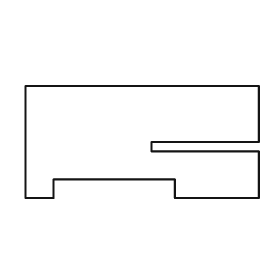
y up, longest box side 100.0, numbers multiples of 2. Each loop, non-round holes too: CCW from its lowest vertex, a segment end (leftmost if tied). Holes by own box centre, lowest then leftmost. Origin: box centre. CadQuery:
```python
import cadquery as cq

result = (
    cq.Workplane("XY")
    .moveTo(-50.0, -24.0)
    .lineTo(-38.0, -24.0)
    .lineTo(-38.0, -16.0)
    .lineTo(14.0, -16.0)
    .lineTo(14.0, -24.0)
    .lineTo(50.0, -24.0)
    .lineTo(50.0, -4.0)
    .lineTo(4.0, -4.0)
    .lineTo(4.0, 0.0)
    .lineTo(50.0, 0.0)
    .lineTo(50.0, 24.0)
    .lineTo(-50.0, 24.0)
    .close()
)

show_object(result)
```